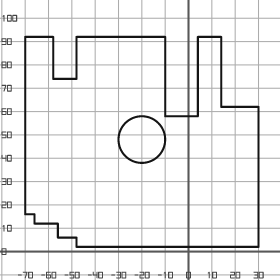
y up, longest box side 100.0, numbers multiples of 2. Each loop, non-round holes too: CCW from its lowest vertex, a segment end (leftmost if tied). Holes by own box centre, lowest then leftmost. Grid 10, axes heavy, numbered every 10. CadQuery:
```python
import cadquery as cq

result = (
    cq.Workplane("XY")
    .moveTo(-48.0, 2.0)
    .lineTo(30.0, 2.0)
    .lineTo(30.0, 62.0)
    .lineTo(14.0, 62.0)
    .lineTo(14.0, 92.0)
    .lineTo(4.0, 92.0)
    .lineTo(4.0, 58.0)
    .lineTo(-10.0, 58.0)
    .lineTo(-10.0, 92.0)
    .lineTo(-48.0, 92.0)
    .lineTo(-48.0, 74.0)
    .lineTo(-58.0, 74.0)
    .lineTo(-58.0, 92.0)
    .lineTo(-70.0, 92.0)
    .lineTo(-70.0, 16.0)
    .lineTo(-66.0, 16.0)
    .lineTo(-66.0, 12.0)
    .lineTo(-56.0, 12.0)
    .lineTo(-56.0, 6.0)
    .lineTo(-48.0, 6.0)
    .close()
    .moveTo(-20.0, 48.0)
    .circle(10.0)
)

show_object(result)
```